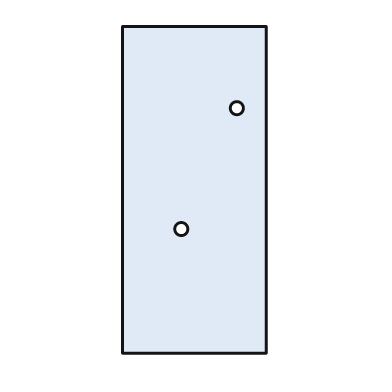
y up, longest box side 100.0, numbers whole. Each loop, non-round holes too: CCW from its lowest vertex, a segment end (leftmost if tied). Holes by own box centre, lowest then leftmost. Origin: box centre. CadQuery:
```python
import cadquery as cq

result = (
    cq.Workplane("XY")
    .moveTo(-22.0, -50.0)
    .lineTo(22.0, -50.0)
    .lineTo(22.0, 50.0)
    .lineTo(-22.0, 50.0)
    .close()
    .moveTo(-4.0, -12.0)
    .circle(2.0)
    .moveTo(13.0, 25.0)
    .circle(2.0)
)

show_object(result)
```